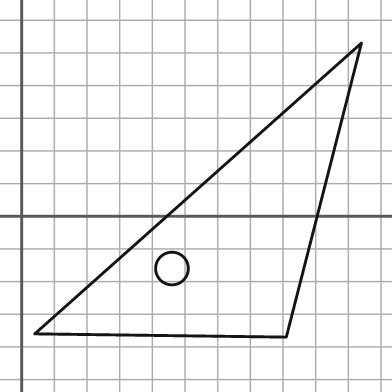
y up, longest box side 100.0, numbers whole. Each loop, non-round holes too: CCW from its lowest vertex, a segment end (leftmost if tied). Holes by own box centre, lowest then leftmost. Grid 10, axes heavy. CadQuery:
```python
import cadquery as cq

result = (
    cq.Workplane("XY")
    .moveTo(81.0, -37.0)
    .lineTo(104.0, 53.0)
    .lineTo(4.0, -36.0)
    .close()
    .moveTo(46.0, -16.0)
    .circle(5.0)
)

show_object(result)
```